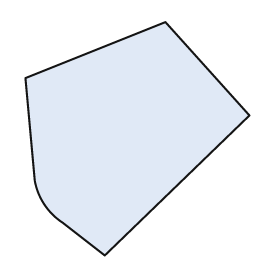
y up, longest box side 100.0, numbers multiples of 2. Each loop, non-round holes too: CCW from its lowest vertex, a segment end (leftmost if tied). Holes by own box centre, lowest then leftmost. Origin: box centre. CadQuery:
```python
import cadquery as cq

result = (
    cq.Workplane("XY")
    .moveTo(-14.0, -50.0)
    .lineTo(48.0, 10.0)
    .lineTo(12.0, 50.0)
    .lineTo(-48.0, 26.0)
    .lineTo(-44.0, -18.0)
    .threePointArc((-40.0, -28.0), (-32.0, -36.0))
    .close()
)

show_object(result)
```